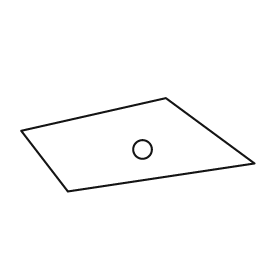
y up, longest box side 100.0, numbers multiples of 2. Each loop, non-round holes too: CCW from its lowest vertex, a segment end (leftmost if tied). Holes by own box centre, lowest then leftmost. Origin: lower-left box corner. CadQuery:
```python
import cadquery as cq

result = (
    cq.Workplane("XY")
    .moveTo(20.0, 0.0)
    .lineTo(100.0, 12.0)
    .lineTo(62.0, 40.0)
    .lineTo(0.0, 26.0)
    .close()
    .moveTo(52.0, 18.0)
    .circle(4.0)
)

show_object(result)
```